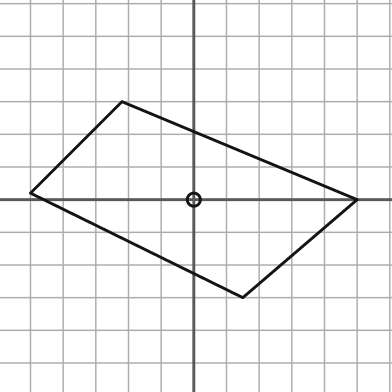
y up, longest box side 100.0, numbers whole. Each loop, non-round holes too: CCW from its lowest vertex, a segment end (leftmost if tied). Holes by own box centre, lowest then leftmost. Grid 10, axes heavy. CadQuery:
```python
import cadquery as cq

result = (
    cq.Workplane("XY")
    .moveTo(15.0, -30.0)
    .lineTo(50.0, 0.0)
    .lineTo(-22.0, 30.0)
    .lineTo(-50.0, 2.0)
    .close()
    .moveTo(0.0, 0.0)
    .circle(2.0)
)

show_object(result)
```